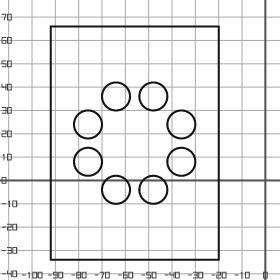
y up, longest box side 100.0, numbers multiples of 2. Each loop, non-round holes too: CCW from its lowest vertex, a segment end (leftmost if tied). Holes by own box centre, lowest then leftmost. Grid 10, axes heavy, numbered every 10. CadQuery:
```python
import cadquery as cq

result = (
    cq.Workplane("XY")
    .moveTo(-92.0, -34.0)
    .lineTo(-20.0, -34.0)
    .lineTo(-20.0, 66.0)
    .lineTo(-92.0, 66.0)
    .close()
    .moveTo(-64.0, -4.0)
    .circle(6.0)
    .moveTo(-48.0, -4.0)
    .circle(6.0)
    .moveTo(-76.0, 8.0)
    .circle(6.0)
    .moveTo(-36.0, 8.0)
    .circle(6.0)
    .moveTo(-76.0, 24.0)
    .circle(6.0)
    .moveTo(-36.0, 24.0)
    .circle(6.0)
    .moveTo(-64.0, 36.0)
    .circle(6.0)
    .moveTo(-48.0, 36.0)
    .circle(6.0)
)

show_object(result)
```